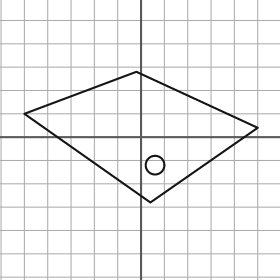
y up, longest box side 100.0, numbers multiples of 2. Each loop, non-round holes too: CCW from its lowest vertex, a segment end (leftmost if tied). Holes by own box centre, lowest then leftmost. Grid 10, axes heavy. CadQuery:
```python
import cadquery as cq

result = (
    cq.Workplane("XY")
    .moveTo(4.0, -28.0)
    .lineTo(50.0, 4.0)
    .lineTo(-2.0, 28.0)
    .lineTo(-50.0, 10.0)
    .close()
    .moveTo(6.0, -12.0)
    .circle(4.0)
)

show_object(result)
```